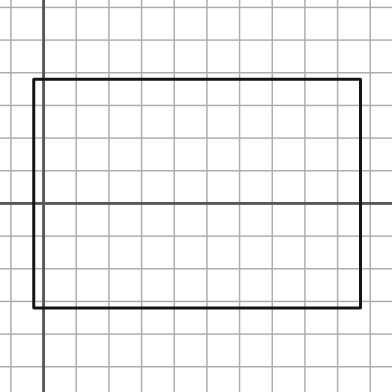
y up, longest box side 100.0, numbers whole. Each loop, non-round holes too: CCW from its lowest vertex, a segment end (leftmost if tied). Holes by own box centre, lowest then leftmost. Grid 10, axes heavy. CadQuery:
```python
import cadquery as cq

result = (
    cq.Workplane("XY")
    .moveTo(-3.0, -32.0)
    .lineTo(97.0, -32.0)
    .lineTo(97.0, 38.0)
    .lineTo(-3.0, 38.0)
    .close()
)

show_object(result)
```